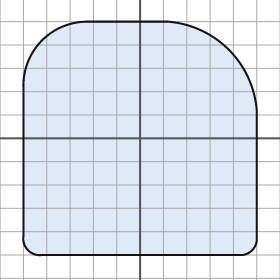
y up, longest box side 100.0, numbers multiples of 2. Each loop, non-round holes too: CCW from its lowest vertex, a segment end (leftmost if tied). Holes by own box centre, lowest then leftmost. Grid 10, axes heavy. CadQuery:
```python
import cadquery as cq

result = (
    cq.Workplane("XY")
    .moveTo(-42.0, -50.0)
    .lineTo(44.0, -50.0)
    .threePointArc((48.0, -48.0), (50.0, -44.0))
    .lineTo(50.0, 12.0)
    .threePointArc((38.0, 38.0), (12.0, 50.0))
    .lineTo(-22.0, 50.0)
    .threePointArc((-42.0, 42.0), (-50.0, 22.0))
    .lineTo(-50.0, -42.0)
    .threePointArc((-48.0, -48.0), (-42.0, -50.0))
    .close()
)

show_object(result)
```